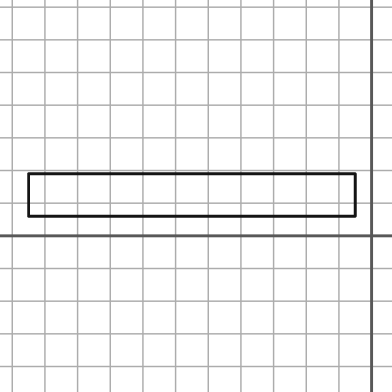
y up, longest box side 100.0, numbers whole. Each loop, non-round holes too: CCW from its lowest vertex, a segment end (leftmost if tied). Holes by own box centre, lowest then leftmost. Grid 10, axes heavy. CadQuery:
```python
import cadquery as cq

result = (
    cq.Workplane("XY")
    .moveTo(-105.0, 6.0)
    .lineTo(-5.0, 6.0)
    .lineTo(-5.0, 19.0)
    .lineTo(-105.0, 19.0)
    .close()
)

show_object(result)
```